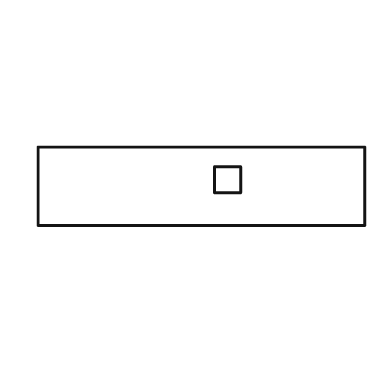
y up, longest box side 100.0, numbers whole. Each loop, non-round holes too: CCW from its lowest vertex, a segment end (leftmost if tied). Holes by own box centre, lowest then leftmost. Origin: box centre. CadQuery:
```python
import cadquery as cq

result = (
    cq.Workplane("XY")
    .moveTo(-50.0, -12.0)
    .lineTo(50.0, -12.0)
    .lineTo(50.0, 12.0)
    .lineTo(-50.0, 12.0)
    .close()
    .moveTo(4.0, -2.0)
    .lineTo(12.0, -2.0)
    .lineTo(12.0, 6.0)
    .lineTo(4.0, 6.0)
    .close()
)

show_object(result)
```